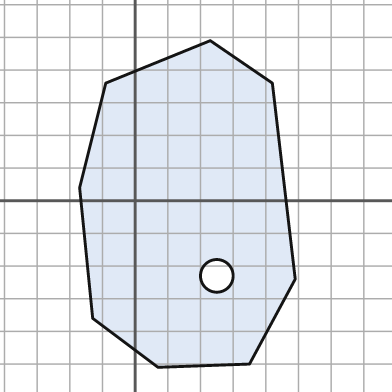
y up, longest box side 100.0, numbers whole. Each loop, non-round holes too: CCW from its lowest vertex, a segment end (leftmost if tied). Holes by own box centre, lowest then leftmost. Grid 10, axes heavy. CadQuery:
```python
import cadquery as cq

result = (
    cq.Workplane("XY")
    .moveTo(7.0, -51.0)
    .lineTo(35.0, -50.0)
    .lineTo(49.0, -24.0)
    .lineTo(42.0, 36.0)
    .lineTo(23.0, 49.0)
    .lineTo(-9.0, 36.0)
    .lineTo(-17.0, 4.0)
    .lineTo(-13.0, -36.0)
    .close()
    .moveTo(25.0, -23.0)
    .circle(5.0)
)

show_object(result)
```